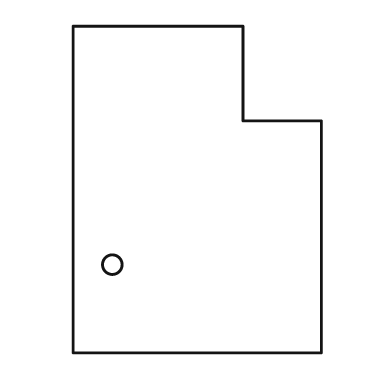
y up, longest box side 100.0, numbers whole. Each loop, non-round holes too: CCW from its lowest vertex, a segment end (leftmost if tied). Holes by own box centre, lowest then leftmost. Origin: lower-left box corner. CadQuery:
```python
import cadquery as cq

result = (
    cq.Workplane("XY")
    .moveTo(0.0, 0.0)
    .lineTo(76.0, 0.0)
    .lineTo(76.0, 71.0)
    .lineTo(52.0, 71.0)
    .lineTo(52.0, 100.0)
    .lineTo(0.0, 100.0)
    .close()
    .moveTo(12.0, 27.0)
    .circle(3.0)
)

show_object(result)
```